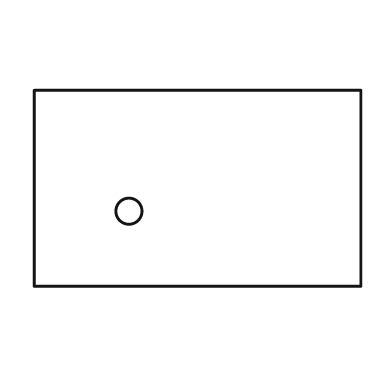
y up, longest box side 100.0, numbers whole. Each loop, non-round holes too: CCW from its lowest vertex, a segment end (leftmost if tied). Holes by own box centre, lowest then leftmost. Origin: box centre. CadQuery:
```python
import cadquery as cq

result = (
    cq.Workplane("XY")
    .moveTo(-50.0, -30.0)
    .lineTo(50.0, -30.0)
    .lineTo(50.0, 30.0)
    .lineTo(-50.0, 30.0)
    .close()
    .moveTo(-21.0, -7.0)
    .circle(4.0)
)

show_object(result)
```